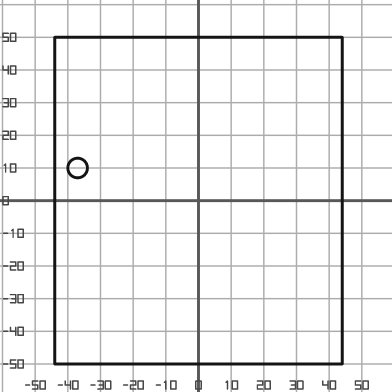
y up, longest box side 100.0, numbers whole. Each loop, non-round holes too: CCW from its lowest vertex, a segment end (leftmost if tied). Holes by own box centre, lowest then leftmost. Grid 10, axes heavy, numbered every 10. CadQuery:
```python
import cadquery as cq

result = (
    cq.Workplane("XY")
    .moveTo(-44.0, -50.0)
    .lineTo(44.0, -50.0)
    .lineTo(44.0, 50.0)
    .lineTo(-44.0, 50.0)
    .close()
    .moveTo(-37.0, 10.0)
    .circle(3.0)
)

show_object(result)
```